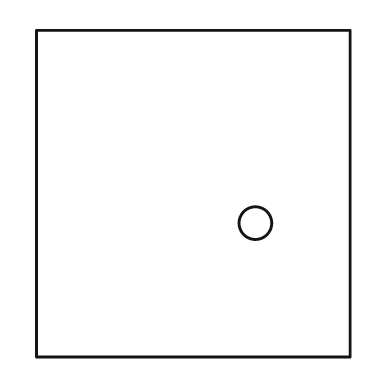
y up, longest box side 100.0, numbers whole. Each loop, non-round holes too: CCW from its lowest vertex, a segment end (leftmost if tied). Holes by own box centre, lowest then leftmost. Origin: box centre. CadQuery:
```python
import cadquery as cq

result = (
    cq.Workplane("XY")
    .moveTo(-48.0, -50.0)
    .lineTo(48.0, -50.0)
    .lineTo(48.0, 50.0)
    .lineTo(-48.0, 50.0)
    .close()
    .moveTo(19.0, -9.0)
    .circle(5.0)
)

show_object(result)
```